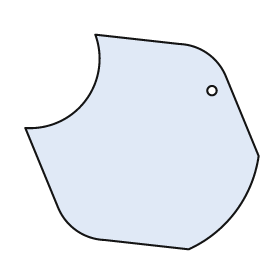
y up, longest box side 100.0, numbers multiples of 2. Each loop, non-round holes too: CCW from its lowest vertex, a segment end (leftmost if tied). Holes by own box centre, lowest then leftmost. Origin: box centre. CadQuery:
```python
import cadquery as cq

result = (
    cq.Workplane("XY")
    .moveTo(20.0, -46.0)
    .threePointArc((40.0, -30.0), (50.0, -6.0))
    .lineTo(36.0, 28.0)
    .threePointArc((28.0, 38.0), (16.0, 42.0))
    .lineTo(-20.0, 46.0)
    .threePointArc((-24.0, 18.0), (-50.0, 6.0))
    .lineTo(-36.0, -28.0)
    .threePointArc((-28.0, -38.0), (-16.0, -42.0))
    .close()
    .moveTo(30.0, 22.0)
    .circle(2.0)
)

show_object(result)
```